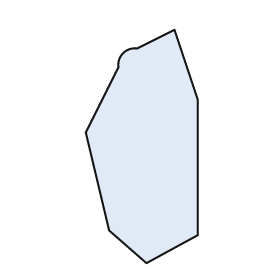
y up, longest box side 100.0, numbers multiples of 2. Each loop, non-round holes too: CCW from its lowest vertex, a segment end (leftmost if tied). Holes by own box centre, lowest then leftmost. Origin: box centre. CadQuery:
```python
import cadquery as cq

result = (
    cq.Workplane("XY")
    .moveTo(2.0, -50.0)
    .lineTo(24.0, -38.0)
    .lineTo(24.0, 20.0)
    .lineTo(14.0, 50.0)
    .lineTo(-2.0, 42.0)
    .threePointArc((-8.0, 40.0), (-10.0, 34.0))
    .lineTo(-24.0, 6.0)
    .lineTo(-14.0, -36.0)
    .close()
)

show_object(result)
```